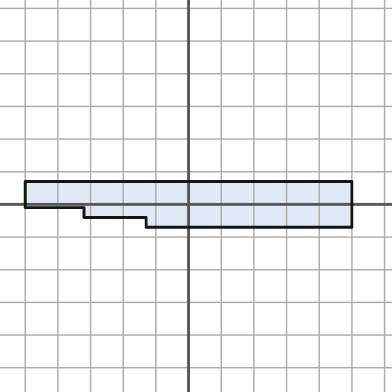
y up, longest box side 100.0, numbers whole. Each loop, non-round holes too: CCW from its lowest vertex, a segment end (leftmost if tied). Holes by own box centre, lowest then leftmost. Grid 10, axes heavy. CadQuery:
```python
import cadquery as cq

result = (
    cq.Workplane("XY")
    .moveTo(-13.0, -7.0)
    .lineTo(50.0, -7.0)
    .lineTo(50.0, 7.0)
    .lineTo(-50.0, 7.0)
    .lineTo(-50.0, -1.0)
    .lineTo(-32.0, -1.0)
    .lineTo(-32.0, -4.0)
    .lineTo(-13.0, -4.0)
    .close()
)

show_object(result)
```